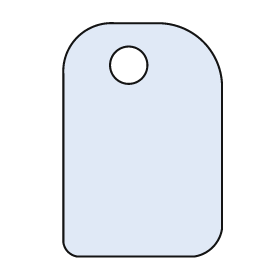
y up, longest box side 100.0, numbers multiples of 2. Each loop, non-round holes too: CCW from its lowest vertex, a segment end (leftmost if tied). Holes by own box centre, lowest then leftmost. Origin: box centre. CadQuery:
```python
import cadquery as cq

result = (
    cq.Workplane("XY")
    .moveTo(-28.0, -50.0)
    .lineTo(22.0, -50.0)
    .threePointArc((30.0, -46.0), (34.0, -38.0))
    .lineTo(34.0, 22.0)
    .threePointArc((26.0, 42.0), (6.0, 50.0))
    .lineTo(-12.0, 50.0)
    .threePointArc((-28.0, 44.0), (-34.0, 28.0))
    .lineTo(-34.0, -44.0)
    .threePointArc((-32.0, -48.0), (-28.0, -50.0))
    .close()
    .moveTo(-6.0, 32.0)
    .circle(8.0)
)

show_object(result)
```